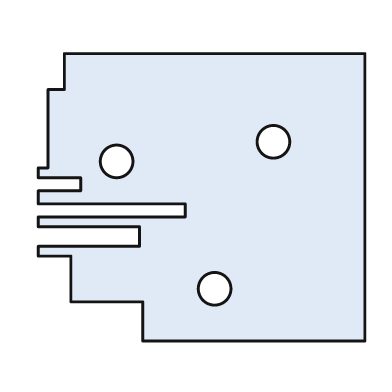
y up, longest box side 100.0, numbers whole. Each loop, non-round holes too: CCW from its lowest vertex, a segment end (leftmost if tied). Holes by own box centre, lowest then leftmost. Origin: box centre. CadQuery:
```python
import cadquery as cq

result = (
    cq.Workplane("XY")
    .moveTo(-18.0, -44.0)
    .lineTo(50.0, -44.0)
    .lineTo(50.0, 44.0)
    .lineTo(-42.0, 44.0)
    .lineTo(-42.0, 33.0)
    .lineTo(-47.0, 33.0)
    .lineTo(-47.0, 9.0)
    .lineTo(-50.0, 9.0)
    .lineTo(-50.0, 6.0)
    .lineTo(-37.0, 6.0)
    .lineTo(-37.0, 2.0)
    .lineTo(-50.0, 2.0)
    .lineTo(-50.0, -2.0)
    .lineTo(-5.0, -2.0)
    .lineTo(-5.0, -6.0)
    .lineTo(-50.0, -6.0)
    .lineTo(-50.0, -9.0)
    .lineTo(-19.0, -9.0)
    .lineTo(-19.0, -15.0)
    .lineTo(-50.0, -15.0)
    .lineTo(-50.0, -18.0)
    .lineTo(-40.0, -18.0)
    .lineTo(-40.0, -32.0)
    .lineTo(-18.0, -32.0)
    .close()
    .moveTo(4.0, -28.0)
    .circle(5.0)
    .moveTo(-26.0, 11.0)
    .circle(5.0)
    .moveTo(22.0, 17.0)
    .circle(5.0)
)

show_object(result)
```